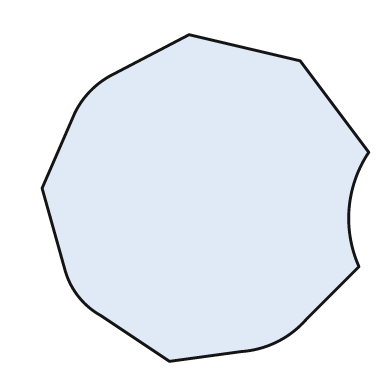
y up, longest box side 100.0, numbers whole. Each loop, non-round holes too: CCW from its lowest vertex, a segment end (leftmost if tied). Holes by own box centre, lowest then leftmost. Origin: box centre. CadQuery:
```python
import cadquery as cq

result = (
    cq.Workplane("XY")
    .moveTo(-11.0, -50.0)
    .lineTo(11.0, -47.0)
    .threePointArc((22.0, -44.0), (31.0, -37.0))
    .lineTo(47.0, -21.0)
    .threePointArc((44.0, -3.0), (50.0, 14.0))
    .lineTo(29.0, 42.0)
    .lineTo(-5.0, 50.0)
    .lineTo(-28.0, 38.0)
    .threePointArc((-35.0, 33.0), (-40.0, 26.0))
    .lineTo(-50.0, 3.0)
    .lineTo(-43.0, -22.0)
    .threePointArc((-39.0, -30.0), (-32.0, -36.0))
    .close()
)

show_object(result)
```